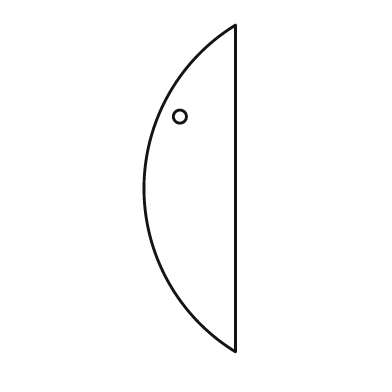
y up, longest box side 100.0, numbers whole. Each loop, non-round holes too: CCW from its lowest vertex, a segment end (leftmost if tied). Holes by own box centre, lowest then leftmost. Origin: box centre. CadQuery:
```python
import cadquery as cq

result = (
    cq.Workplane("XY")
    .moveTo(14.0, -50.0)
    .lineTo(14.0, 50.0)
    .threePointArc((-14.0, 0.0), (14.0, -50.0))
    .close()
    .moveTo(-3.0, 22.0)
    .circle(2.0)
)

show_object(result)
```